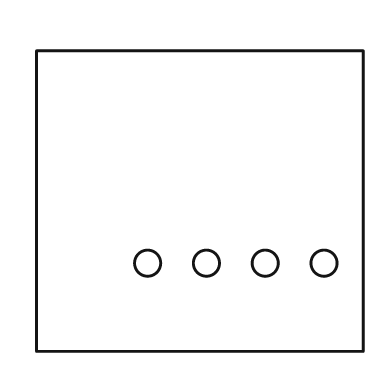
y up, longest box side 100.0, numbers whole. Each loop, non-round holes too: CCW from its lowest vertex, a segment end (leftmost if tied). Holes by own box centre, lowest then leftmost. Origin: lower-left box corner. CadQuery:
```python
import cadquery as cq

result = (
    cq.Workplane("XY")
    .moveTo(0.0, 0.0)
    .lineTo(100.0, 0.0)
    .lineTo(100.0, 92.0)
    .lineTo(0.0, 92.0)
    .close()
    .moveTo(34.0, 27.0)
    .circle(4.0)
    .moveTo(52.0, 27.0)
    .circle(4.0)
    .moveTo(70.0, 27.0)
    .circle(4.0)
    .moveTo(88.0, 27.0)
    .circle(4.0)
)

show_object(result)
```